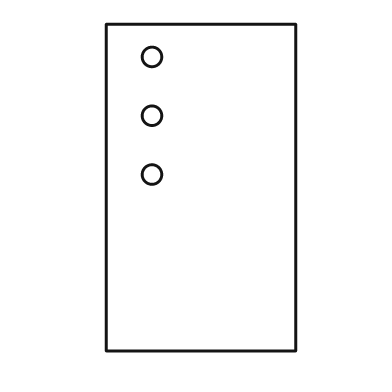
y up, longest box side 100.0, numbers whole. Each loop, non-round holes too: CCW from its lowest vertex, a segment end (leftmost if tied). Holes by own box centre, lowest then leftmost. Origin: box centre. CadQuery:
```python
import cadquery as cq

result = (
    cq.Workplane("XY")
    .moveTo(-29.0, -50.0)
    .lineTo(29.0, -50.0)
    .lineTo(29.0, 50.0)
    .lineTo(-29.0, 50.0)
    .close()
    .moveTo(-15.0, 4.0)
    .circle(3.0)
    .moveTo(-15.0, 22.0)
    .circle(3.0)
    .moveTo(-15.0, 40.0)
    .circle(3.0)
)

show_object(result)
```